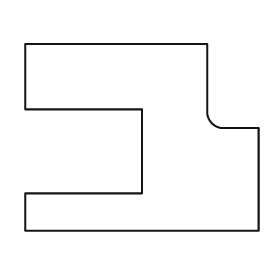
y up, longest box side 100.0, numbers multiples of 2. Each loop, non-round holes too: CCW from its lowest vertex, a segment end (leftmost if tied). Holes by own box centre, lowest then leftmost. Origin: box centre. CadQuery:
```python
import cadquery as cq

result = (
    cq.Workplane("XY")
    .moveTo(-50.0, -40.0)
    .lineTo(50.0, -40.0)
    .lineTo(50.0, 4.0)
    .lineTo(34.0, 4.0)
    .threePointArc((30.0, 6.0), (28.0, 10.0))
    .lineTo(28.0, 40.0)
    .lineTo(-50.0, 40.0)
    .lineTo(-50.0, 12.0)
    .lineTo(0.0, 12.0)
    .lineTo(0.0, -24.0)
    .lineTo(-50.0, -24.0)
    .close()
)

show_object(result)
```